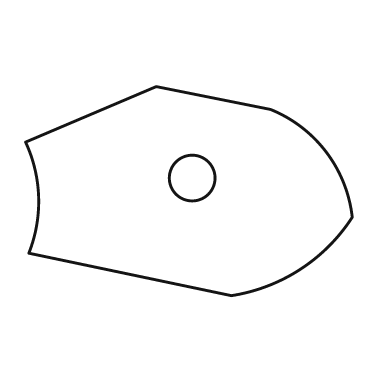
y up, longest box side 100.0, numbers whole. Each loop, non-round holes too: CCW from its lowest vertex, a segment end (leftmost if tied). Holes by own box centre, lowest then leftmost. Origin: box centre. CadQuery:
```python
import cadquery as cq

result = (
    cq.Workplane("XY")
    .moveTo(13.0, -32.0)
    .threePointArc((34.0, -24.0), (50.0, -8.0))
    .threePointArc((42.0, 12.0), (25.0, 25.0))
    .lineTo(-10.0, 32.0)
    .lineTo(-50.0, 15.0)
    .threePointArc((-46.0, -2.0), (-49.0, -19.0))
    .close()
    .moveTo(1.0, 4.0)
    .circle(7.0)
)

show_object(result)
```